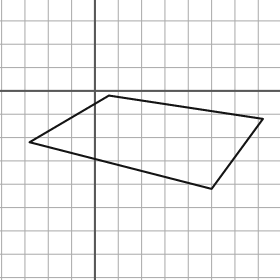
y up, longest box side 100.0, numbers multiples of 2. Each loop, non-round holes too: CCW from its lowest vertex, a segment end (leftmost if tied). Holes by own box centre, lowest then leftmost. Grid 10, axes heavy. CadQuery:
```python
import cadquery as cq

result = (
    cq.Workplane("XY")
    .moveTo(50.0, -42.0)
    .lineTo(72.0, -12.0)
    .lineTo(6.0, -2.0)
    .lineTo(-28.0, -22.0)
    .close()
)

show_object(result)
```